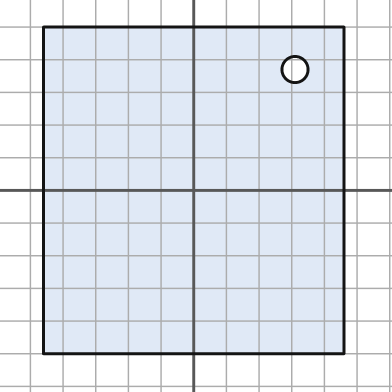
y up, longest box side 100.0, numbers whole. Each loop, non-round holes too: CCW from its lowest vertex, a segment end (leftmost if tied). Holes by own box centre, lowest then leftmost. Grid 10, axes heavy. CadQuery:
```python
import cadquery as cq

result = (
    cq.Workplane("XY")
    .moveTo(-46.0, -50.0)
    .lineTo(46.0, -50.0)
    .lineTo(46.0, 50.0)
    .lineTo(-46.0, 50.0)
    .close()
    .moveTo(31.0, 37.0)
    .circle(4.0)
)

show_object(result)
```